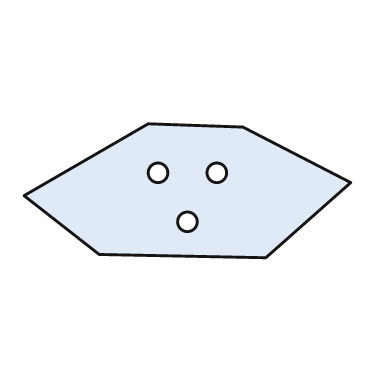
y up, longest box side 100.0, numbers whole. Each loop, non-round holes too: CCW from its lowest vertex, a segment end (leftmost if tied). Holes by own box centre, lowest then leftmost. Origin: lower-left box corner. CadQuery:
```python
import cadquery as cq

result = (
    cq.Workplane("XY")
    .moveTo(74.0, 0.0)
    .lineTo(100.0, 23.0)
    .lineTo(67.0, 40.0)
    .lineTo(38.0, 41.0)
    .lineTo(0.0, 19.0)
    .lineTo(23.0, 1.0)
    .close()
    .moveTo(50.0, 11.0)
    .circle(3.0)
    .moveTo(41.0, 26.0)
    .circle(3.0)
    .moveTo(59.0, 26.0)
    .circle(3.0)
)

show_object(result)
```